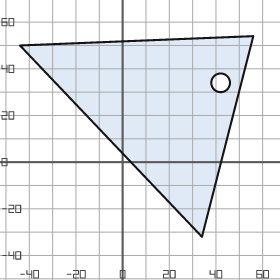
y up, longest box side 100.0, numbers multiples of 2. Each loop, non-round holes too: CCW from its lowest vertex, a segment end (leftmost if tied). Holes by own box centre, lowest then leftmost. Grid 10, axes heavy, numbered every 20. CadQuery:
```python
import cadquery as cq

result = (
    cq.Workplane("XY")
    .moveTo(34.0, -32.0)
    .lineTo(56.0, 54.0)
    .lineTo(-44.0, 50.0)
    .close()
    .moveTo(42.0, 34.0)
    .circle(4.0)
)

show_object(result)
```